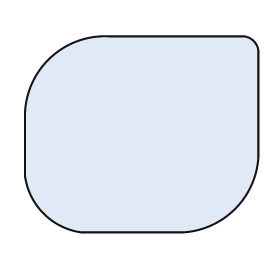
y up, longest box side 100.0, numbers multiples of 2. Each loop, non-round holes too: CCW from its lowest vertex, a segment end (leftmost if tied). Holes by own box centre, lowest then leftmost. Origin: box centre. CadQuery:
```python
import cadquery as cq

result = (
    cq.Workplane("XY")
    .moveTo(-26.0, -42.0)
    .lineTo(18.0, -42.0)
    .threePointArc((40.0, -32.0), (50.0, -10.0))
    .lineTo(50.0, 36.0)
    .threePointArc((48.0, 40.0), (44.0, 42.0))
    .lineTo(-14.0, 42.0)
    .threePointArc((-40.0, 32.0), (-50.0, 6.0))
    .lineTo(-50.0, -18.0)
    .threePointArc((-42.0, -34.0), (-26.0, -42.0))
    .close()
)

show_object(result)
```